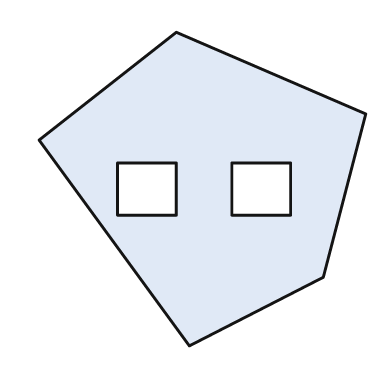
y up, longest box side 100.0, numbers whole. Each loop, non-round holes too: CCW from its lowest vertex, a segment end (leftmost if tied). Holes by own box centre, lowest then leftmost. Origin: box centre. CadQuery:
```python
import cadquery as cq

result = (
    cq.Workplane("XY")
    .moveTo(-4.0, -48.0)
    .lineTo(37.0, -27.0)
    .lineTo(50.0, 23.0)
    .lineTo(-8.0, 48.0)
    .lineTo(-50.0, 15.0)
    .close()
    .moveTo(-26.0, -8.0)
    .lineTo(-8.0, -8.0)
    .lineTo(-8.0, 8.0)
    .lineTo(-26.0, 8.0)
    .close()
    .moveTo(9.0, -8.0)
    .lineTo(27.0, -8.0)
    .lineTo(27.0, 8.0)
    .lineTo(9.0, 8.0)
    .close()
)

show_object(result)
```